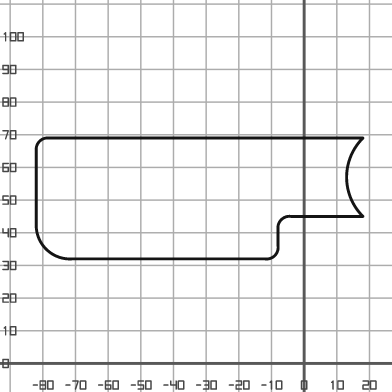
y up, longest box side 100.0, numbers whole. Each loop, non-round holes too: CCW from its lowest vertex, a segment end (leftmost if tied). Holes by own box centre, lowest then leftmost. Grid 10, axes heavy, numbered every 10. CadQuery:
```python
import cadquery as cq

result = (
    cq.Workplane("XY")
    .moveTo(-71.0, 32.0)
    .lineTo(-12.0, 32.0)
    .threePointArc((-9.0, 33.0), (-8.0, 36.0))
    .lineTo(-8.0, 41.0)
    .threePointArc((-7.0, 44.0), (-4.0, 45.0))
    .lineTo(18.0, 45.0)
    .threePointArc((13.0, 57.0), (18.0, 69.0))
    .lineTo(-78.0, 69.0)
    .threePointArc((-81.0, 68.0), (-82.0, 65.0))
    .lineTo(-82.0, 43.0)
    .threePointArc((-79.0, 35.0), (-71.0, 32.0))
    .close()
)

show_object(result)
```